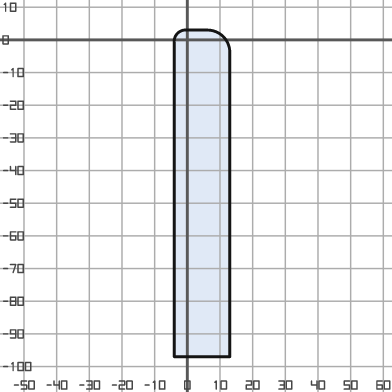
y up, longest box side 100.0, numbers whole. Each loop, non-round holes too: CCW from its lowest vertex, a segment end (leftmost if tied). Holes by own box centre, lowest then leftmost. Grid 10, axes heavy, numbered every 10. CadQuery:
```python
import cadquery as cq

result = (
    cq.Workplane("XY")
    .moveTo(-4.0, -97.0)
    .lineTo(13.0, -97.0)
    .lineTo(13.0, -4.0)
    .threePointArc((11.0, 1.0), (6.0, 3.0))
    .lineTo(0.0, 3.0)
    .threePointArc((-3.0, 2.0), (-4.0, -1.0))
    .close()
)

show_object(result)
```